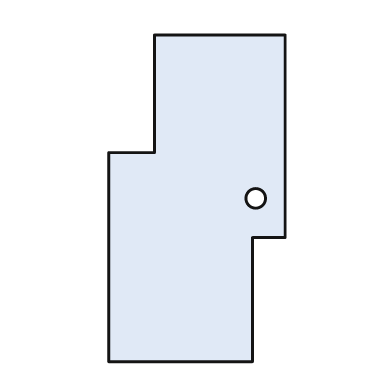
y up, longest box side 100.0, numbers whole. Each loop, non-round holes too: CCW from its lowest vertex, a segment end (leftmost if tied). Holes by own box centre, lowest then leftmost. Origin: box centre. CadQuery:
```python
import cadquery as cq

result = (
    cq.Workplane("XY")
    .moveTo(-27.0, -50.0)
    .lineTo(17.0, -50.0)
    .lineTo(17.0, -12.0)
    .lineTo(27.0, -12.0)
    .lineTo(27.0, 50.0)
    .lineTo(-13.0, 50.0)
    .lineTo(-13.0, 14.0)
    .lineTo(-27.0, 14.0)
    .close()
    .moveTo(18.0, 0.0)
    .circle(3.0)
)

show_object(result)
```